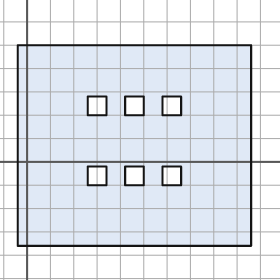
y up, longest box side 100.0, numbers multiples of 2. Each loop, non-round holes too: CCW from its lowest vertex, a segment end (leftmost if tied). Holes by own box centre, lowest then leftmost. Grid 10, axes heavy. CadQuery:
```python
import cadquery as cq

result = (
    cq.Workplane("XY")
    .moveTo(-4.0, -36.0)
    .lineTo(96.0, -36.0)
    .lineTo(96.0, 50.0)
    .lineTo(-4.0, 50.0)
    .close()
    .moveTo(26.0, -10.0)
    .lineTo(34.0, -10.0)
    .lineTo(34.0, -2.0)
    .lineTo(26.0, -2.0)
    .close()
    .moveTo(42.0, -10.0)
    .lineTo(50.0, -10.0)
    .lineTo(50.0, -2.0)
    .lineTo(42.0, -2.0)
    .close()
    .moveTo(58.0, -10.0)
    .lineTo(66.0, -10.0)
    .lineTo(66.0, -2.0)
    .lineTo(58.0, -2.0)
    .close()
    .moveTo(26.0, 20.0)
    .lineTo(34.0, 20.0)
    .lineTo(34.0, 28.0)
    .lineTo(26.0, 28.0)
    .close()
    .moveTo(42.0, 20.0)
    .lineTo(50.0, 20.0)
    .lineTo(50.0, 28.0)
    .lineTo(42.0, 28.0)
    .close()
    .moveTo(58.0, 20.0)
    .lineTo(66.0, 20.0)
    .lineTo(66.0, 28.0)
    .lineTo(58.0, 28.0)
    .close()
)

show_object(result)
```